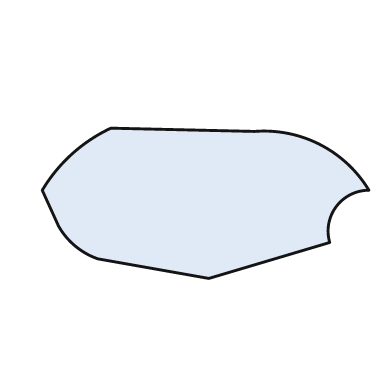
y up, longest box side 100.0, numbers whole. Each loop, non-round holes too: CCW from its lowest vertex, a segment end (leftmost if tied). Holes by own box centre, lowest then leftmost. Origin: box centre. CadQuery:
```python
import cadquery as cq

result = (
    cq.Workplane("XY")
    .moveTo(1.0, -23.0)
    .lineTo(38.0, -12.0)
    .threePointArc((40.0, -1.0), (50.0, 4.0))
    .threePointArc((35.0, 18.0), (15.0, 22.0))
    .lineTo(-29.0, 23.0)
    .threePointArc((-41.0, 15.0), (-50.0, 4.0))
    .lineTo(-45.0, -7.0)
    .threePointArc((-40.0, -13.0), (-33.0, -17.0))
    .close()
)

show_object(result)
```